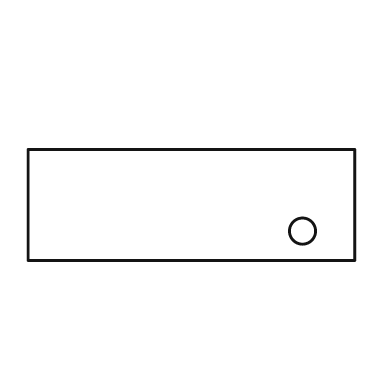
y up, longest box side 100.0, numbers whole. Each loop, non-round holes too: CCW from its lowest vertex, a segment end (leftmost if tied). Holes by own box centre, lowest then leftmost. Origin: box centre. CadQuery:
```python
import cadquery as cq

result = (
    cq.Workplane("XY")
    .moveTo(-50.0, -17.0)
    .lineTo(50.0, -17.0)
    .lineTo(50.0, 17.0)
    .lineTo(-50.0, 17.0)
    .close()
    .moveTo(34.0, -8.0)
    .circle(4.0)
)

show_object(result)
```